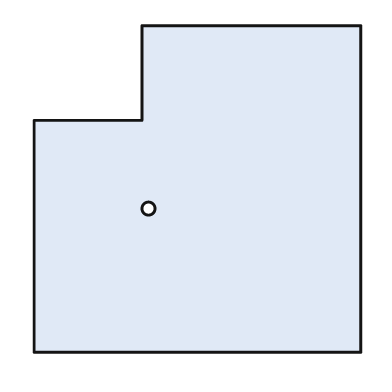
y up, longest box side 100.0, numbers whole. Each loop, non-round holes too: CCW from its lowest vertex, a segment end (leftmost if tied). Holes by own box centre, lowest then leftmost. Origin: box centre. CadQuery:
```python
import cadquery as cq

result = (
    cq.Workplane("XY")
    .moveTo(-50.0, -50.0)
    .lineTo(50.0, -50.0)
    .lineTo(50.0, 50.0)
    .lineTo(-17.0, 50.0)
    .lineTo(-17.0, 21.0)
    .lineTo(-50.0, 21.0)
    .close()
    .moveTo(-15.0, -6.0)
    .circle(2.0)
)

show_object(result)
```